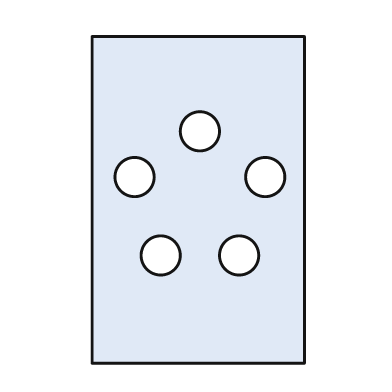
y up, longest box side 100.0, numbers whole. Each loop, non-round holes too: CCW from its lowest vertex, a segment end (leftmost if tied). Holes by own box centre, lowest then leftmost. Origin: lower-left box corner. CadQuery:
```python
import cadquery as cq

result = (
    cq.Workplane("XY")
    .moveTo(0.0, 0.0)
    .lineTo(65.0, 0.0)
    .lineTo(65.0, 100.0)
    .lineTo(0.0, 100.0)
    .close()
    .moveTo(21.0, 33.0)
    .circle(6.0)
    .moveTo(45.0, 33.0)
    .circle(6.0)
    .moveTo(13.0, 57.0)
    .circle(6.0)
    .moveTo(53.0, 57.0)
    .circle(6.0)
    .moveTo(33.0, 71.0)
    .circle(6.0)
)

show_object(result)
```